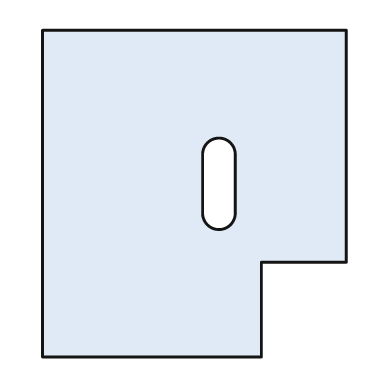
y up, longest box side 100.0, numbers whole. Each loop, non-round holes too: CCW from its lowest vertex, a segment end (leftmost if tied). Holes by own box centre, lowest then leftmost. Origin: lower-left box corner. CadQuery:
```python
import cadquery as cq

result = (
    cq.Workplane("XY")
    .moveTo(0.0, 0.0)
    .lineTo(67.0, 0.0)
    .lineTo(67.0, 29.0)
    .lineTo(93.0, 29.0)
    .lineTo(93.0, 100.0)
    .lineTo(0.0, 100.0)
    .close()
    .moveTo(49.0, 44.0)
    .threePointArc((54.0, 39.0), (59.0, 44.0))
    .lineTo(59.0, 62.0)
    .threePointArc((54.0, 67.0), (49.0, 62.0))
    .close()
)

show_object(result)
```